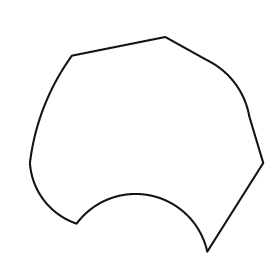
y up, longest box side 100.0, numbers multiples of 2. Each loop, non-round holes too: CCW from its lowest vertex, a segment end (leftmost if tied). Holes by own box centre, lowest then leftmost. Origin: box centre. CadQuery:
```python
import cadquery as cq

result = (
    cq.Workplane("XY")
    .moveTo(26.0, -46.0)
    .lineTo(50.0, -8.0)
    .lineTo(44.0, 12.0)
    .threePointArc((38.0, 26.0), (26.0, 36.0))
    .lineTo(8.0, 46.0)
    .lineTo(-32.0, 38.0)
    .threePointArc((-44.0, 16.0), (-50.0, -8.0))
    .threePointArc((-44.0, -24.0), (-30.0, -34.0))
    .threePointArc((2.0, -22.0), (26.0, -46.0))
    .close()
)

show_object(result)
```